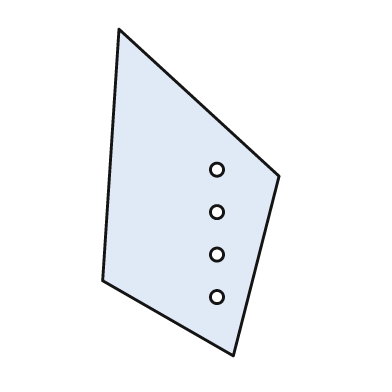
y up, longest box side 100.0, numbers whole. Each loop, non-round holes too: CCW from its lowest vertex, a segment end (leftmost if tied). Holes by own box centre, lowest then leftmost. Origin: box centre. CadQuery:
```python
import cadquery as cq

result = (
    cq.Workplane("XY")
    .moveTo(13.0, -50.0)
    .lineTo(27.0, 5.0)
    .lineTo(-22.0, 50.0)
    .lineTo(-27.0, -27.0)
    .close()
    .moveTo(8.0, -32.0)
    .circle(2.0)
    .moveTo(8.0, -19.0)
    .circle(2.0)
    .moveTo(8.0, -6.0)
    .circle(2.0)
    .moveTo(8.0, 7.0)
    .circle(2.0)
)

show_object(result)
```